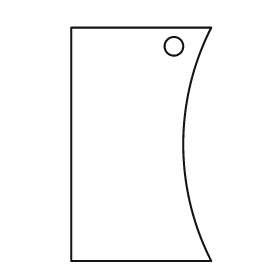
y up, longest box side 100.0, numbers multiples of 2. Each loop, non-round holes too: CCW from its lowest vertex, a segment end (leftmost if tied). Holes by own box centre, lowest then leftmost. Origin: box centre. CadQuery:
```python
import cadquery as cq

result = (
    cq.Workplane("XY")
    .moveTo(-30.0, -50.0)
    .lineTo(30.0, -50.0)
    .threePointArc((18.0, 0.0), (30.0, 50.0))
    .lineTo(-30.0, 50.0)
    .close()
    .moveTo(14.0, 42.0)
    .circle(4.0)
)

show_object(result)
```